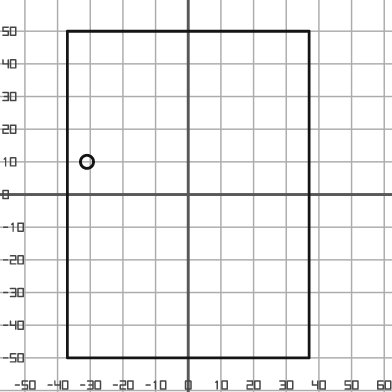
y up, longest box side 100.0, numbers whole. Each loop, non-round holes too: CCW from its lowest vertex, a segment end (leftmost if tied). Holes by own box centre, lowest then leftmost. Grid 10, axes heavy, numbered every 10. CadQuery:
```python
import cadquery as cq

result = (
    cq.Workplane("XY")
    .moveTo(-37.0, -50.0)
    .lineTo(37.0, -50.0)
    .lineTo(37.0, 50.0)
    .lineTo(-37.0, 50.0)
    .close()
    .moveTo(-31.0, 10.0)
    .circle(2.0)
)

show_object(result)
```